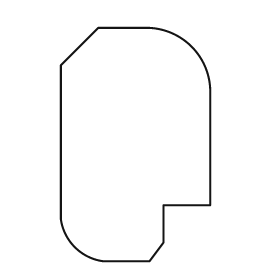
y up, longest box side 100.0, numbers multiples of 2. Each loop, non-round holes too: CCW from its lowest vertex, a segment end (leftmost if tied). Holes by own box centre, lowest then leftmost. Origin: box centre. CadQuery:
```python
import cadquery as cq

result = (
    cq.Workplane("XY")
    .moveTo(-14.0, -50.0)
    .lineTo(6.0, -50.0)
    .lineTo(12.0, -42.0)
    .lineTo(12.0, -26.0)
    .lineTo(32.0, -26.0)
    .lineTo(32.0, 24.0)
    .threePointArc((24.0, 42.0), (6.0, 50.0))
    .lineTo(-16.0, 50.0)
    .lineTo(-32.0, 34.0)
    .lineTo(-32.0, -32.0)
    .threePointArc((-26.0, -44.0), (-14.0, -50.0))
    .close()
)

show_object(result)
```